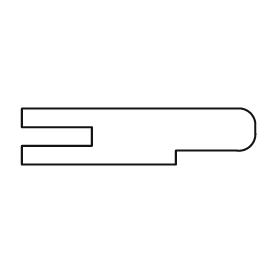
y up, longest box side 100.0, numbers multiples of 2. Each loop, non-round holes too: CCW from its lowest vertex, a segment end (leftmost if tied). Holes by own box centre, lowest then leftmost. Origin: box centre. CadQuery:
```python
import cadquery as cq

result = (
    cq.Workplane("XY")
    .moveTo(-50.0, -12.0)
    .lineTo(16.0, -12.0)
    .lineTo(16.0, -6.0)
    .lineTo(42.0, -6.0)
    .threePointArc((48.0, -4.0), (50.0, 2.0))
    .lineTo(50.0, 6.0)
    .threePointArc((48.0, 10.0), (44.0, 12.0))
    .lineTo(-50.0, 12.0)
    .lineTo(-50.0, 4.0)
    .lineTo(-20.0, 4.0)
    .lineTo(-20.0, -4.0)
    .lineTo(-50.0, -4.0)
    .close()
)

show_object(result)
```